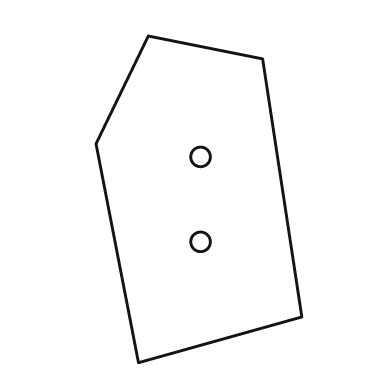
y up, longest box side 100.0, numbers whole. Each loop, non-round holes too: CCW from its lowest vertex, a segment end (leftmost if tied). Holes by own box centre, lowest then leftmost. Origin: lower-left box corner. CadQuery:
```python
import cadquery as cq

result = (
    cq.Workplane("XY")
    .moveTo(13.0, 0.0)
    .lineTo(63.0, 14.0)
    .lineTo(51.0, 93.0)
    .lineTo(16.0, 100.0)
    .lineTo(0.0, 67.0)
    .close()
    .moveTo(32.0, 37.0)
    .circle(3.0)
    .moveTo(32.0, 63.0)
    .circle(3.0)
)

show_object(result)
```